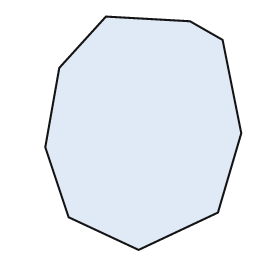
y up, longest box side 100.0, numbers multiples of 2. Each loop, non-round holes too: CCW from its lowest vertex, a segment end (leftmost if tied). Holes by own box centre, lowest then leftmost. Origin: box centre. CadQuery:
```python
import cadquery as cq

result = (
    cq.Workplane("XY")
    .moveTo(-2.0, -50.0)
    .lineTo(32.0, -34.0)
    .lineTo(42.0, 0.0)
    .lineTo(34.0, 40.0)
    .lineTo(20.0, 48.0)
    .lineTo(-16.0, 50.0)
    .lineTo(-36.0, 28.0)
    .lineTo(-42.0, -6.0)
    .lineTo(-32.0, -36.0)
    .close()
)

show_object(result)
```